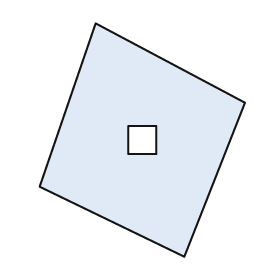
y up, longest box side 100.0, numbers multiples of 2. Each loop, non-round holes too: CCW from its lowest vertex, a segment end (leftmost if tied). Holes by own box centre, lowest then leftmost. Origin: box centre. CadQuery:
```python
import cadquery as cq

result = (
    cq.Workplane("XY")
    .moveTo(18.0, -50.0)
    .lineTo(44.0, 16.0)
    .lineTo(-20.0, 50.0)
    .lineTo(-44.0, -20.0)
    .close()
    .moveTo(-6.0, -6.0)
    .lineTo(6.0, -6.0)
    .lineTo(6.0, 6.0)
    .lineTo(-6.0, 6.0)
    .close()
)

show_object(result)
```